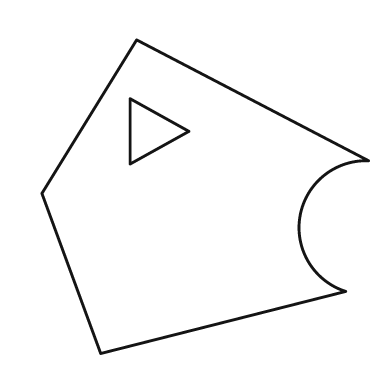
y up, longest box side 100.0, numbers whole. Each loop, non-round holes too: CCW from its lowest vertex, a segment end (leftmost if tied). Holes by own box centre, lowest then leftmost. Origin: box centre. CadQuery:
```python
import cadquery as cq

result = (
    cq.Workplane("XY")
    .moveTo(-32.0, -48.0)
    .lineTo(43.0, -29.0)
    .threePointArc((29.0, -6.0), (50.0, 11.0))
    .lineTo(-21.0, 48.0)
    .lineTo(-50.0, 1.0)
    .close()
    .moveTo(-23.0, 10.0)
    .lineTo(-5.0, 20.0)
    .lineTo(-23.0, 30.0)
    .close()
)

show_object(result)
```